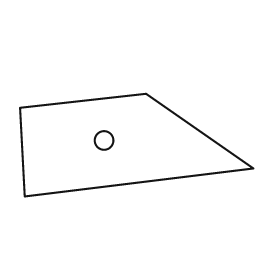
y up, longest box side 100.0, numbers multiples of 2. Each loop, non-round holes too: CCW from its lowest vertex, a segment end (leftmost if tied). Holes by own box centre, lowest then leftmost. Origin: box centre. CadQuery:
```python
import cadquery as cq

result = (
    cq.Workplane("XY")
    .moveTo(-48.0, -22.0)
    .lineTo(50.0, -10.0)
    .lineTo(4.0, 22.0)
    .lineTo(-50.0, 16.0)
    .close()
    .moveTo(-14.0, 2.0)
    .circle(4.0)
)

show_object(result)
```